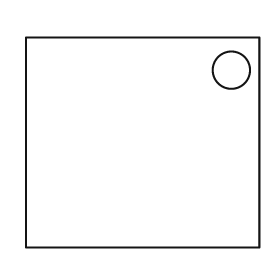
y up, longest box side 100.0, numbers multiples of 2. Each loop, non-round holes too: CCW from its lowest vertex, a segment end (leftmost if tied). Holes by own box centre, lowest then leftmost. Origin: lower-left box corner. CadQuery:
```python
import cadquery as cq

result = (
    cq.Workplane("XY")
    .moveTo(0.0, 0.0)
    .lineTo(100.0, 0.0)
    .lineTo(100.0, 90.0)
    .lineTo(0.0, 90.0)
    .close()
    .moveTo(88.0, 76.0)
    .circle(8.0)
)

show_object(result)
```